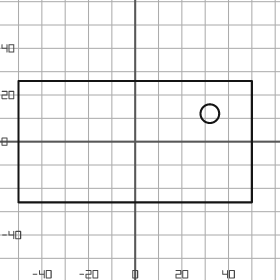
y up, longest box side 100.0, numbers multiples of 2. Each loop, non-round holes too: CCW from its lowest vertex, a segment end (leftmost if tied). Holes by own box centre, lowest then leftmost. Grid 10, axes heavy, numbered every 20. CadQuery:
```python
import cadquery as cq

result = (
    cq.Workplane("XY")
    .moveTo(-50.0, -26.0)
    .lineTo(50.0, -26.0)
    .lineTo(50.0, 26.0)
    .lineTo(-50.0, 26.0)
    .close()
    .moveTo(32.0, 12.0)
    .circle(4.0)
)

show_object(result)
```